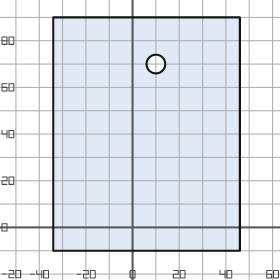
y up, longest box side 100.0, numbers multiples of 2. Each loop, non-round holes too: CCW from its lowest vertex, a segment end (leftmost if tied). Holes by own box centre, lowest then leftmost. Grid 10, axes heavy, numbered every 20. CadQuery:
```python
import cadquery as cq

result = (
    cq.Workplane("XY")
    .moveTo(-34.0, -10.0)
    .lineTo(46.0, -10.0)
    .lineTo(46.0, 90.0)
    .lineTo(-34.0, 90.0)
    .close()
    .moveTo(10.0, 70.0)
    .circle(4.0)
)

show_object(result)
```